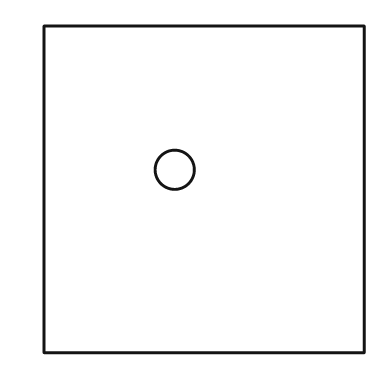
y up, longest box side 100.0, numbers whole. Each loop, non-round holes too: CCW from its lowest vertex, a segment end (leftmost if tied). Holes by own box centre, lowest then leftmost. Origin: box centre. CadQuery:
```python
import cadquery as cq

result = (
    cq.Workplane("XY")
    .moveTo(-49.0, -50.0)
    .lineTo(49.0, -50.0)
    .lineTo(49.0, 50.0)
    .lineTo(-49.0, 50.0)
    .close()
    .moveTo(-9.0, 6.0)
    .circle(6.0)
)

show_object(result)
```